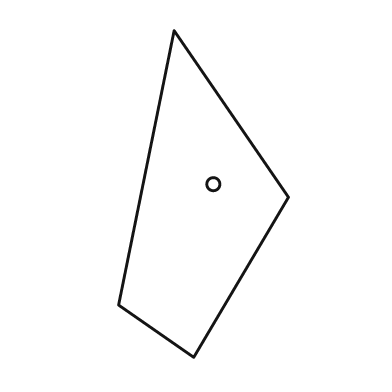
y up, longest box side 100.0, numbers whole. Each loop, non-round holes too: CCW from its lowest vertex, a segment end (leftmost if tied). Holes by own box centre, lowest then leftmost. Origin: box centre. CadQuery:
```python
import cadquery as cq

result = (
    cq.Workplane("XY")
    .moveTo(-3.0, -50.0)
    .lineTo(26.0, -1.0)
    .lineTo(-9.0, 50.0)
    .lineTo(-26.0, -34.0)
    .close()
    .moveTo(3.0, 3.0)
    .circle(2.0)
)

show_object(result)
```